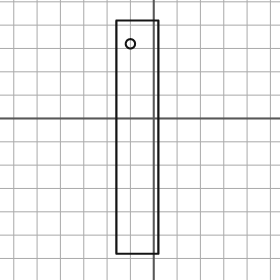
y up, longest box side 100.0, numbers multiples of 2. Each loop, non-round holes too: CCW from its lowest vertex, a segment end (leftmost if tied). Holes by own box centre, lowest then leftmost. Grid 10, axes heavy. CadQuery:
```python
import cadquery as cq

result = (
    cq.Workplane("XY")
    .moveTo(-16.0, -58.0)
    .lineTo(2.0, -58.0)
    .lineTo(2.0, 42.0)
    .lineTo(-16.0, 42.0)
    .close()
    .moveTo(-10.0, 32.0)
    .circle(2.0)
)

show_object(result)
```